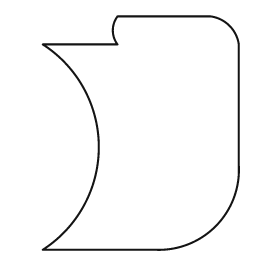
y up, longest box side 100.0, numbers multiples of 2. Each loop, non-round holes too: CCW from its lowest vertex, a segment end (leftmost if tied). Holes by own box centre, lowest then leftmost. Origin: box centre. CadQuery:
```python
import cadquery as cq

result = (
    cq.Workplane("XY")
    .moveTo(-42.0, -50.0)
    .lineTo(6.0, -50.0)
    .threePointArc((32.0, -40.0), (42.0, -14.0))
    .lineTo(42.0, 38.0)
    .threePointArc((38.0, 46.0), (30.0, 50.0))
    .lineTo(-10.0, 50.0)
    .threePointArc((-12.0, 44.0), (-10.0, 38.0))
    .lineTo(-42.0, 38.0)
    .threePointArc((-18.0, -6.0), (-42.0, -50.0))
    .close()
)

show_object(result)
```